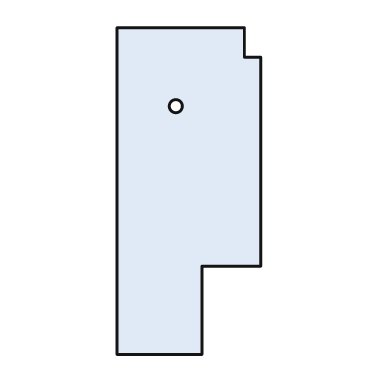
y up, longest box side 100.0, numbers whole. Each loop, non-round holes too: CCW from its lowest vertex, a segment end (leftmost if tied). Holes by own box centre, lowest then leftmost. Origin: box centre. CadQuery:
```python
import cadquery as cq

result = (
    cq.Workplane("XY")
    .moveTo(-22.0, -50.0)
    .lineTo(4.0, -50.0)
    .lineTo(4.0, -23.0)
    .lineTo(22.0, -23.0)
    .lineTo(22.0, 41.0)
    .lineTo(17.0, 41.0)
    .lineTo(17.0, 50.0)
    .lineTo(-22.0, 50.0)
    .close()
    .moveTo(-4.0, 26.0)
    .circle(2.0)
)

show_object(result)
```